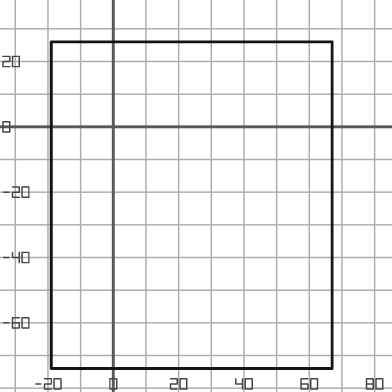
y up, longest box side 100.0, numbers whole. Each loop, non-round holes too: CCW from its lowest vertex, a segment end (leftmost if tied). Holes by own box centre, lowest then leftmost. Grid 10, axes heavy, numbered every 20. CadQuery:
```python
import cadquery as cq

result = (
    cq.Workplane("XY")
    .moveTo(-19.0, -74.0)
    .lineTo(67.0, -74.0)
    .lineTo(67.0, 26.0)
    .lineTo(-19.0, 26.0)
    .close()
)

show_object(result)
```